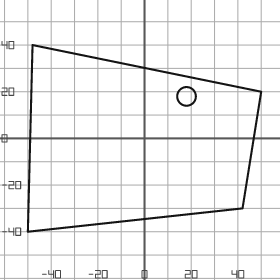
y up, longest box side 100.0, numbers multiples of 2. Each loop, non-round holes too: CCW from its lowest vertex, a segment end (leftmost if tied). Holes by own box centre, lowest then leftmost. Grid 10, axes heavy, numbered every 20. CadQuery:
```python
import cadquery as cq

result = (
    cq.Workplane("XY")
    .moveTo(-50.0, -40.0)
    .lineTo(42.0, -30.0)
    .lineTo(50.0, 20.0)
    .lineTo(-48.0, 40.0)
    .close()
    .moveTo(18.0, 18.0)
    .circle(4.0)
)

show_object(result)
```